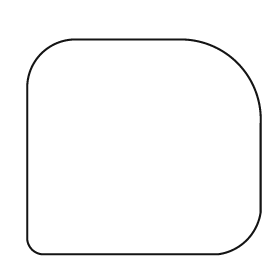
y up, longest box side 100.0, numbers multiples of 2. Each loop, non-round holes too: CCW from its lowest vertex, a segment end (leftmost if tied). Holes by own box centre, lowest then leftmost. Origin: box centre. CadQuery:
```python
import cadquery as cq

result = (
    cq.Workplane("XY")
    .moveTo(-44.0, -46.0)
    .lineTo(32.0, -46.0)
    .threePointArc((44.0, -40.0), (50.0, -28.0))
    .lineTo(50.0, 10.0)
    .threePointArc((40.0, 36.0), (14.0, 46.0))
    .lineTo(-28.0, 46.0)
    .threePointArc((-44.0, 40.0), (-50.0, 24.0))
    .lineTo(-50.0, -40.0)
    .threePointArc((-48.0, -44.0), (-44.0, -46.0))
    .close()
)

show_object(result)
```